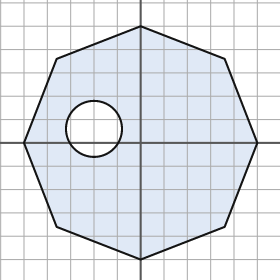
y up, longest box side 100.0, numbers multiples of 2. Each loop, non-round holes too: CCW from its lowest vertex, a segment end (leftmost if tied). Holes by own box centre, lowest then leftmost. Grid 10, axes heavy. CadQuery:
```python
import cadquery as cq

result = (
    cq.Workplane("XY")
    .moveTo(0.0, -50.0)
    .lineTo(36.0, -36.0)
    .lineTo(50.0, 0.0)
    .lineTo(36.0, 36.0)
    .lineTo(0.0, 50.0)
    .lineTo(-36.0, 36.0)
    .lineTo(-50.0, 0.0)
    .lineTo(-36.0, -36.0)
    .close()
    .moveTo(-20.0, 6.0)
    .circle(12.0)
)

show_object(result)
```